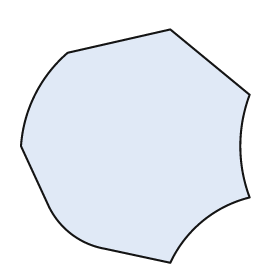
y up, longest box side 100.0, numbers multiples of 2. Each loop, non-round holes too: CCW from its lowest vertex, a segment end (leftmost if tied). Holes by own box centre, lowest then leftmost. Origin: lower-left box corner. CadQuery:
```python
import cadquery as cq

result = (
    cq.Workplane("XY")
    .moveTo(64.0, 0.0)
    .threePointArc((78.0, 18.0), (98.0, 28.0))
    .threePointArc((94.0, 50.0), (98.0, 72.0))
    .lineTo(64.0, 100.0)
    .lineTo(20.0, 90.0)
    .threePointArc((6.0, 72.0), (0.0, 50.0))
    .lineTo(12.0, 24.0)
    .threePointArc((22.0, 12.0), (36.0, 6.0))
    .close()
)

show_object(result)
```